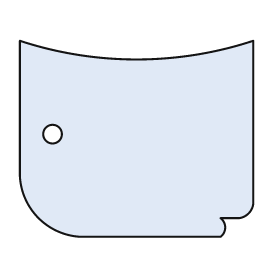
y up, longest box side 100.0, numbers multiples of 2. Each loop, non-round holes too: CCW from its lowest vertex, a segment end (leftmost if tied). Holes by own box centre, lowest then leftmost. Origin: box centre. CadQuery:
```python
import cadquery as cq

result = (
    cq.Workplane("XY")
    .moveTo(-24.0, -42.0)
    .lineTo(36.0, -42.0)
    .threePointArc((38.0, -38.0), (36.0, -34.0))
    .lineTo(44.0, -34.0)
    .threePointArc((48.0, -32.0), (50.0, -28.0))
    .lineTo(50.0, 42.0)
    .threePointArc((0.0, 34.0), (-50.0, 42.0))
    .lineTo(-50.0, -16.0)
    .threePointArc((-42.0, -34.0), (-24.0, -42.0))
    .close()
    .moveTo(-36.0, 2.0)
    .circle(4.0)
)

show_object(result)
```